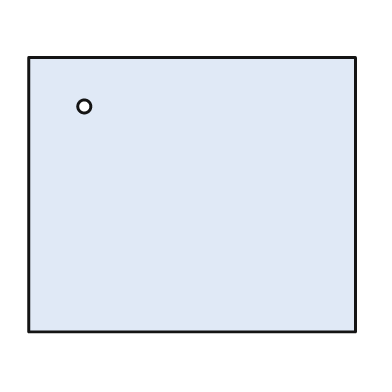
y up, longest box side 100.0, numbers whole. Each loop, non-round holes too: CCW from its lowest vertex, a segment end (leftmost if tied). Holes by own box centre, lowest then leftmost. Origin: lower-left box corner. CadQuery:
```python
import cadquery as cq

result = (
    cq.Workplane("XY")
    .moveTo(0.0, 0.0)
    .lineTo(100.0, 0.0)
    .lineTo(100.0, 84.0)
    .lineTo(0.0, 84.0)
    .close()
    .moveTo(17.0, 69.0)
    .circle(2.0)
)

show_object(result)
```